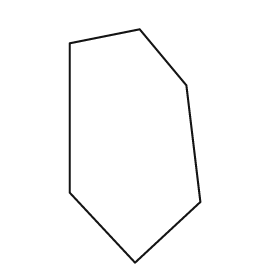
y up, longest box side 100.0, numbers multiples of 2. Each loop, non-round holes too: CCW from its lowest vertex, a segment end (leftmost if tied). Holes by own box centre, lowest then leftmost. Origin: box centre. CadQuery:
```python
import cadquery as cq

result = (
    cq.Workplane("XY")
    .moveTo(0.0, -50.0)
    .lineTo(28.0, -24.0)
    .lineTo(22.0, 26.0)
    .lineTo(2.0, 50.0)
    .lineTo(-28.0, 44.0)
    .lineTo(-28.0, -20.0)
    .close()
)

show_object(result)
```